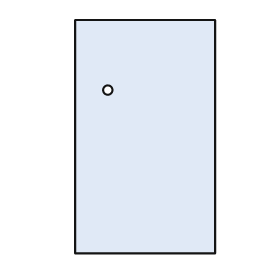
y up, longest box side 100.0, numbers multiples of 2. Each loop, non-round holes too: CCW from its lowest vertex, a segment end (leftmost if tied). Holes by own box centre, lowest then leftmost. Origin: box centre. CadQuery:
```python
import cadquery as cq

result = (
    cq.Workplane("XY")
    .moveTo(-30.0, -50.0)
    .lineTo(30.0, -50.0)
    .lineTo(30.0, 50.0)
    .lineTo(-30.0, 50.0)
    .close()
    .moveTo(-16.0, 20.0)
    .circle(2.0)
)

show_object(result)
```